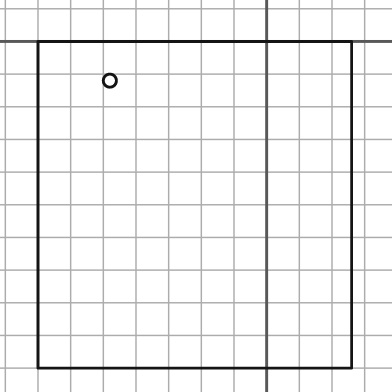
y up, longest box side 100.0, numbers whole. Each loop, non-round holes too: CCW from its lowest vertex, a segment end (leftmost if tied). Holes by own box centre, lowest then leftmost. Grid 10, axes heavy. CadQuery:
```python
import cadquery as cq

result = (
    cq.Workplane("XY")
    .moveTo(-70.0, -100.0)
    .lineTo(26.0, -100.0)
    .lineTo(26.0, 0.0)
    .lineTo(-70.0, 0.0)
    .close()
    .moveTo(-48.0, -12.0)
    .circle(2.0)
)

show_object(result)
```